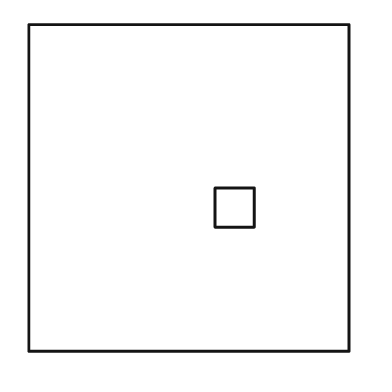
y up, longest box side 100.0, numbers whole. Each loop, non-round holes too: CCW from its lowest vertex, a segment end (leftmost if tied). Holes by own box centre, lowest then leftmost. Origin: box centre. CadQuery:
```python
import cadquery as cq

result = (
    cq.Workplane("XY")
    .moveTo(-49.0, -50.0)
    .lineTo(49.0, -50.0)
    .lineTo(49.0, 50.0)
    .lineTo(-49.0, 50.0)
    .close()
    .moveTo(8.0, -12.0)
    .lineTo(20.0, -12.0)
    .lineTo(20.0, 0.0)
    .lineTo(8.0, 0.0)
    .close()
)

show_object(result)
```